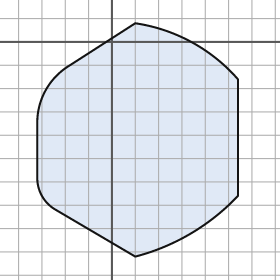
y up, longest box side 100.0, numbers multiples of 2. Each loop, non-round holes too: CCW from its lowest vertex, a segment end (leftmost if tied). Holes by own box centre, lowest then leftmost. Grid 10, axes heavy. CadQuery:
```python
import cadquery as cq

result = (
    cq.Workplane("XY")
    .moveTo(10.0, -92.0)
    .threePointArc((34.0, -82.0), (54.0, -66.0))
    .lineTo(54.0, -16.0)
    .threePointArc((34.0, 0.0), (10.0, 8.0))
    .lineTo(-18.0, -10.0)
    .threePointArc((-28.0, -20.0), (-32.0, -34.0))
    .lineTo(-32.0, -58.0)
    .threePointArc((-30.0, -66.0), (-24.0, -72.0))
    .close()
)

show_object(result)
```